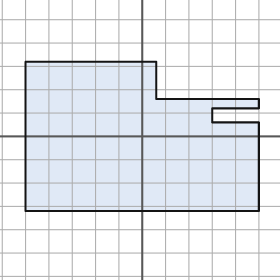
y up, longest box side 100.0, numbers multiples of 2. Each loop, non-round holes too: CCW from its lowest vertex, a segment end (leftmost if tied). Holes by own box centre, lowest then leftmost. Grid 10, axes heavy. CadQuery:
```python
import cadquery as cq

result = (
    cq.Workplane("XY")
    .moveTo(-50.0, -32.0)
    .lineTo(50.0, -32.0)
    .lineTo(50.0, 6.0)
    .lineTo(30.0, 6.0)
    .lineTo(30.0, 12.0)
    .lineTo(50.0, 12.0)
    .lineTo(50.0, 16.0)
    .lineTo(6.0, 16.0)
    .lineTo(6.0, 32.0)
    .lineTo(-50.0, 32.0)
    .close()
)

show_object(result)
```